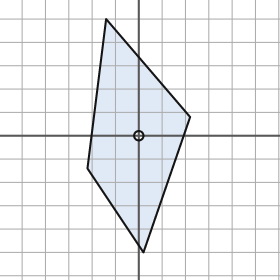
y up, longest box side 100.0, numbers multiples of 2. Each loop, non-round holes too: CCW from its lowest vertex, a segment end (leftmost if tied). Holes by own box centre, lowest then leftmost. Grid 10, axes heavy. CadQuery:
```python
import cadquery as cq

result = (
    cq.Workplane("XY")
    .moveTo(2.0, -50.0)
    .lineTo(22.0, 8.0)
    .lineTo(-14.0, 50.0)
    .lineTo(-22.0, -14.0)
    .close()
    .moveTo(0.0, 0.0)
    .circle(2.0)
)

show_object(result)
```